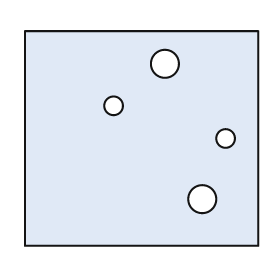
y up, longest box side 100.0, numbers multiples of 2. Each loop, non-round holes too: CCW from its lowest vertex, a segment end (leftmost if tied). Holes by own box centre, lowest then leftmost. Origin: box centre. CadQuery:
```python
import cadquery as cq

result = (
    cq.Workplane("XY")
    .moveTo(-50.0, -46.0)
    .lineTo(50.0, -46.0)
    .lineTo(50.0, 46.0)
    .lineTo(-50.0, 46.0)
    .close()
    .moveTo(26.0, -26.0)
    .circle(6.0)
    .moveTo(36.0, 0.0)
    .circle(4.0)
    .moveTo(-12.0, 14.0)
    .circle(4.0)
    .moveTo(10.0, 32.0)
    .circle(6.0)
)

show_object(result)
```